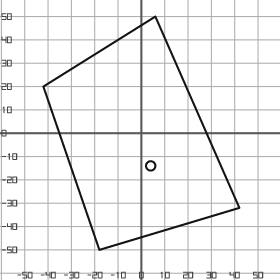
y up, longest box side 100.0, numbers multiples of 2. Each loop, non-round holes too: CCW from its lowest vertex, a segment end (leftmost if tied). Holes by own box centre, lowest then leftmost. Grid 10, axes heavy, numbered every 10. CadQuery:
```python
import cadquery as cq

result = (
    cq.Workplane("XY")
    .moveTo(-18.0, -50.0)
    .lineTo(42.0, -32.0)
    .lineTo(6.0, 50.0)
    .lineTo(-42.0, 20.0)
    .close()
    .moveTo(4.0, -14.0)
    .circle(2.0)
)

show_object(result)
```